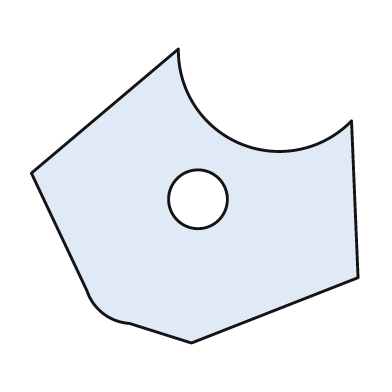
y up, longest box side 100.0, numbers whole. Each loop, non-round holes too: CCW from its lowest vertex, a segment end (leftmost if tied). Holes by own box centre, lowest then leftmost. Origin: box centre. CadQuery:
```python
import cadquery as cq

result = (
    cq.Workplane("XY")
    .moveTo(-1.0, -45.0)
    .lineTo(50.0, -25.0)
    .lineTo(48.0, 23.0)
    .threePointArc((14.0, 16.0), (-5.0, 45.0))
    .lineTo(-50.0, 7.0)
    .lineTo(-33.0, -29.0)
    .threePointArc((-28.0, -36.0), (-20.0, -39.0))
    .close()
    .moveTo(1.0, -1.0)
    .circle(9.0)
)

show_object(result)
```